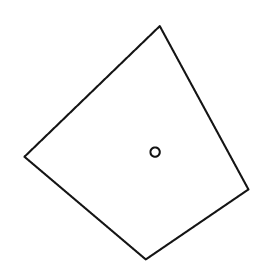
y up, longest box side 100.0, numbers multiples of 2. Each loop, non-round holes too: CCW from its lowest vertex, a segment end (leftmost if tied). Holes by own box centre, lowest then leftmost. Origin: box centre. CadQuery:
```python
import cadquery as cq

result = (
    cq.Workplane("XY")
    .moveTo(4.0, -50.0)
    .lineTo(48.0, -20.0)
    .lineTo(10.0, 50.0)
    .lineTo(-48.0, -6.0)
    .close()
    .moveTo(8.0, -4.0)
    .circle(2.0)
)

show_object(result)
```